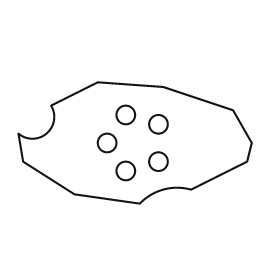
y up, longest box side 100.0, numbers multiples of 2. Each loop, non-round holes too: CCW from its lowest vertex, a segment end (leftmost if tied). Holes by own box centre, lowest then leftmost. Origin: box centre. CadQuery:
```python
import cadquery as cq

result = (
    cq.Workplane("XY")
    .moveTo(2.0, -26.0)
    .threePointArc((12.0, -20.0), (24.0, -20.0))
    .lineTo(48.0, -8.0)
    .lineTo(50.0, 0.0)
    .lineTo(42.0, 14.0)
    .lineTo(12.0, 24.0)
    .lineTo(-16.0, 26.0)
    .lineTo(-36.0, 16.0)
    .threePointArc((-38.0, 4.0), (-50.0, 4.0))
    .lineTo(-48.0, -8.0)
    .lineTo(-26.0, -22.0)
    .close()
    .moveTo(-4.0, -12.0)
    .circle(4.0)
    .moveTo(10.0, -8.0)
    .circle(4.0)
    .moveTo(-12.0, 0.0)
    .circle(4.0)
    .moveTo(10.0, 8.0)
    .circle(4.0)
    .moveTo(-4.0, 12.0)
    .circle(4.0)
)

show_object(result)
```